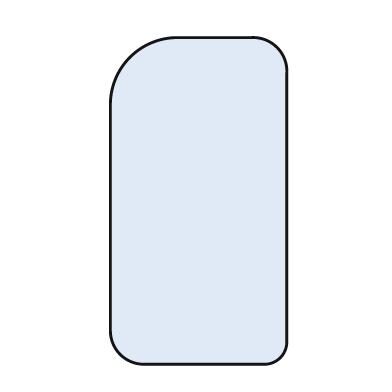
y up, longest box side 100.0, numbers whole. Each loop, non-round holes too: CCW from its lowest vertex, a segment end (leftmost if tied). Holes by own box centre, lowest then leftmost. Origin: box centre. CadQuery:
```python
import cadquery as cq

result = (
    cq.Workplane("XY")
    .moveTo(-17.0, -50.0)
    .lineTo(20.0, -50.0)
    .threePointArc((25.0, -48.0), (27.0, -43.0))
    .lineTo(27.0, 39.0)
    .threePointArc((24.0, 47.0), (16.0, 50.0))
    .lineTo(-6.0, 50.0)
    .threePointArc((-21.0, 44.0), (-27.0, 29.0))
    .lineTo(-27.0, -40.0)
    .threePointArc((-24.0, -47.0), (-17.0, -50.0))
    .close()
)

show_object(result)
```